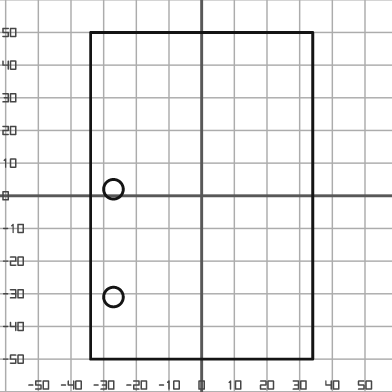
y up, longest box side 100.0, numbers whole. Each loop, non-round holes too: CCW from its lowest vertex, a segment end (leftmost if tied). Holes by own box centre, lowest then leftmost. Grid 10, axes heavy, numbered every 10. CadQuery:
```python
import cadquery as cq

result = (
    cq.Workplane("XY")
    .moveTo(-34.0, -50.0)
    .lineTo(34.0, -50.0)
    .lineTo(34.0, 50.0)
    .lineTo(-34.0, 50.0)
    .close()
    .moveTo(-27.0, -31.0)
    .circle(3.0)
    .moveTo(-27.0, 2.0)
    .circle(3.0)
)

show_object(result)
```